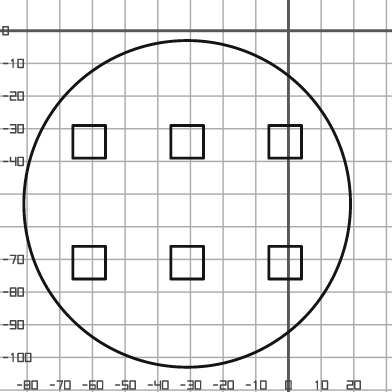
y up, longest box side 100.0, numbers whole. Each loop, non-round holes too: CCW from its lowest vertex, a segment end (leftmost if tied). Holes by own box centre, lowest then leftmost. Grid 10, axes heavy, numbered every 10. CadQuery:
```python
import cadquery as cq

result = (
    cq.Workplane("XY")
    .moveTo(-31.0, -53.0)
    .circle(50.0)
    .moveTo(-66.0, -76.0)
    .lineTo(-56.0, -76.0)
    .lineTo(-56.0, -66.0)
    .lineTo(-66.0, -66.0)
    .close()
    .moveTo(-36.0, -76.0)
    .lineTo(-26.0, -76.0)
    .lineTo(-26.0, -66.0)
    .lineTo(-36.0, -66.0)
    .close()
    .moveTo(-6.0, -76.0)
    .lineTo(4.0, -76.0)
    .lineTo(4.0, -66.0)
    .lineTo(-6.0, -66.0)
    .close()
    .moveTo(-66.0, -39.0)
    .lineTo(-56.0, -39.0)
    .lineTo(-56.0, -29.0)
    .lineTo(-66.0, -29.0)
    .close()
    .moveTo(-36.0, -39.0)
    .lineTo(-26.0, -39.0)
    .lineTo(-26.0, -29.0)
    .lineTo(-36.0, -29.0)
    .close()
    .moveTo(-6.0, -39.0)
    .lineTo(4.0, -39.0)
    .lineTo(4.0, -29.0)
    .lineTo(-6.0, -29.0)
    .close()
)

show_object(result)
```